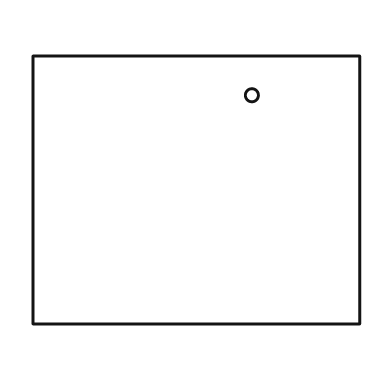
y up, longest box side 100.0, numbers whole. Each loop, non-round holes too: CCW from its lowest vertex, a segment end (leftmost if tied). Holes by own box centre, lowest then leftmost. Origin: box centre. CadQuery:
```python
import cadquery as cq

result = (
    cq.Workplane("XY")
    .moveTo(-50.0, -41.0)
    .lineTo(50.0, -41.0)
    .lineTo(50.0, 41.0)
    .lineTo(-50.0, 41.0)
    .close()
    .moveTo(17.0, 29.0)
    .circle(2.0)
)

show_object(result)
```